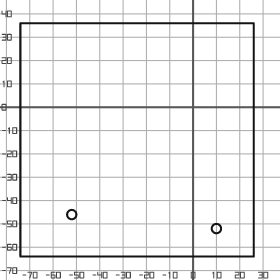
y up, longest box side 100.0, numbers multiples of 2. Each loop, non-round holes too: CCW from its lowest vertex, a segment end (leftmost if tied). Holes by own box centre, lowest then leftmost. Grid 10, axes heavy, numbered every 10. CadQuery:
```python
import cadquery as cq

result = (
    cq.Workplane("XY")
    .moveTo(-74.0, -64.0)
    .lineTo(26.0, -64.0)
    .lineTo(26.0, 36.0)
    .lineTo(-74.0, 36.0)
    .close()
    .moveTo(10.0, -52.0)
    .circle(2.0)
    .moveTo(-52.0, -46.0)
    .circle(2.0)
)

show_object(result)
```